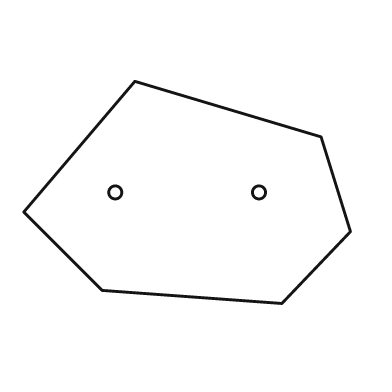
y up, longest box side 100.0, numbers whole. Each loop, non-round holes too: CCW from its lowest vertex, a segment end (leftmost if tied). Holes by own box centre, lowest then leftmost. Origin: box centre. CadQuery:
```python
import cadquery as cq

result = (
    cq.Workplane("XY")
    .moveTo(29.0, -34.0)
    .lineTo(50.0, -12.0)
    .lineTo(41.0, 17.0)
    .lineTo(-16.0, 34.0)
    .lineTo(-50.0, -6.0)
    .lineTo(-26.0, -30.0)
    .close()
    .moveTo(-22.0, 0.0)
    .circle(2.0)
    .moveTo(22.0, 0.0)
    .circle(2.0)
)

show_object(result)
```